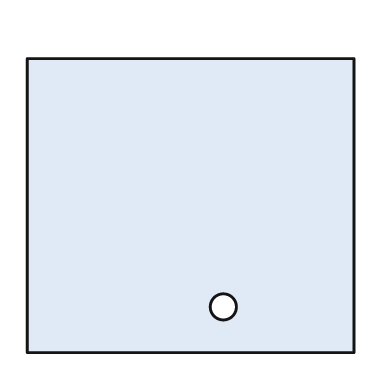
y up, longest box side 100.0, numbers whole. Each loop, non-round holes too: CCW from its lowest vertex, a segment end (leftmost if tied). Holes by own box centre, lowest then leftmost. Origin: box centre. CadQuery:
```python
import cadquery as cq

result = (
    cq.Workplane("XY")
    .moveTo(-50.0, -45.0)
    .lineTo(50.0, -45.0)
    .lineTo(50.0, 45.0)
    .lineTo(-50.0, 45.0)
    .close()
    .moveTo(10.0, -31.0)
    .circle(4.0)
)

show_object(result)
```